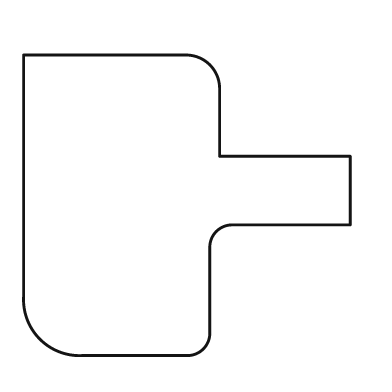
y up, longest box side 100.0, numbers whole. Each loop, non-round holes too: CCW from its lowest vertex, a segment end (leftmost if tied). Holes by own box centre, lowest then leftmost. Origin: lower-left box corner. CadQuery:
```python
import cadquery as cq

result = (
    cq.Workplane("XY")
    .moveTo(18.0, 0.0)
    .lineTo(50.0, 0.0)
    .threePointArc((55.0, 2.0), (57.0, 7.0))
    .lineTo(57.0, 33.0)
    .threePointArc((59.0, 38.0), (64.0, 40.0))
    .lineTo(100.0, 40.0)
    .lineTo(100.0, 61.0)
    .lineTo(60.0, 61.0)
    .lineTo(60.0, 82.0)
    .threePointArc((57.0, 89.0), (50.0, 92.0))
    .lineTo(0.0, 92.0)
    .lineTo(0.0, 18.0)
    .threePointArc((5.0, 5.0), (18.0, 0.0))
    .close()
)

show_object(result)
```